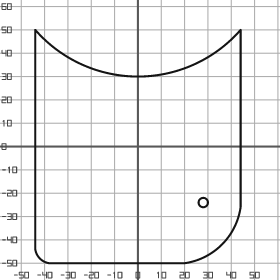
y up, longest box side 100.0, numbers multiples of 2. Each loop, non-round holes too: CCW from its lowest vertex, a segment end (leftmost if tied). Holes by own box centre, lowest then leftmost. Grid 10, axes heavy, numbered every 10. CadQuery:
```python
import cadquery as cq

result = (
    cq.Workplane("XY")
    .moveTo(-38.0, -50.0)
    .lineTo(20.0, -50.0)
    .threePointArc((36.0, -42.0), (44.0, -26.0))
    .lineTo(44.0, 50.0)
    .threePointArc((0.0, 30.0), (-44.0, 50.0))
    .lineTo(-44.0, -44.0)
    .threePointArc((-42.0, -48.0), (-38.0, -50.0))
    .close()
    .moveTo(28.0, -24.0)
    .circle(2.0)
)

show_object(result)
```